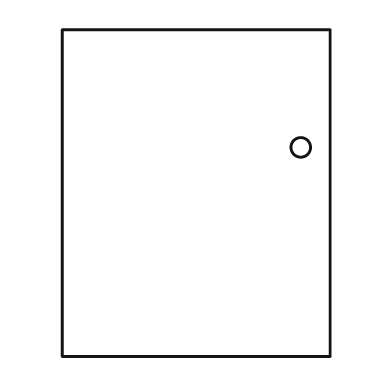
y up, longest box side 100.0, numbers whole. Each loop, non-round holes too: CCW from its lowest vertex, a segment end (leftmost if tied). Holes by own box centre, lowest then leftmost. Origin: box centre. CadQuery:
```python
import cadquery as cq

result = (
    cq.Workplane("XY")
    .moveTo(-41.0, -50.0)
    .lineTo(41.0, -50.0)
    .lineTo(41.0, 50.0)
    .lineTo(-41.0, 50.0)
    .close()
    .moveTo(32.0, 14.0)
    .circle(3.0)
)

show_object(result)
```